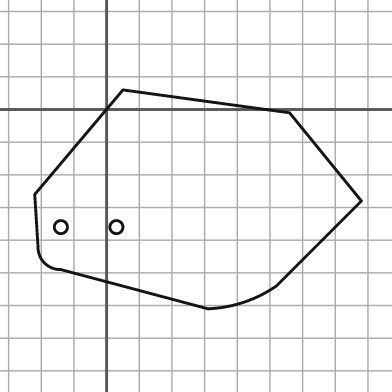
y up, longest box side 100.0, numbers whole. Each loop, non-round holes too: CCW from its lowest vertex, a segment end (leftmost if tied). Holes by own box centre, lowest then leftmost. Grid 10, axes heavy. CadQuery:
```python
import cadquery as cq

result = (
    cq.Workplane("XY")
    .moveTo(31.0, -61.0)
    .threePointArc((42.0, -59.0), (52.0, -54.0))
    .lineTo(78.0, -28.0)
    .lineTo(56.0, -1.0)
    .lineTo(5.0, 6.0)
    .lineTo(-22.0, -26.0)
    .lineTo(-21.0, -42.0)
    .threePointArc((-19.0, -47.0), (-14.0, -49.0))
    .close()
    .moveTo(-14.0, -36.0)
    .circle(2.0)
    .moveTo(3.0, -36.0)
    .circle(2.0)
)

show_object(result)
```